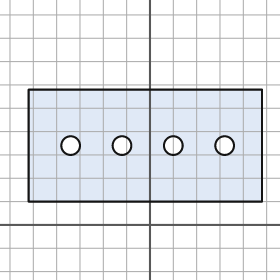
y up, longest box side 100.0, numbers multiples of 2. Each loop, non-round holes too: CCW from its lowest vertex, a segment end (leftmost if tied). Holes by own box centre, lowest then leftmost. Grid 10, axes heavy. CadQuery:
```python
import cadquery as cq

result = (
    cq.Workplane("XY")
    .moveTo(-52.0, 10.0)
    .lineTo(48.0, 10.0)
    .lineTo(48.0, 58.0)
    .lineTo(-52.0, 58.0)
    .close()
    .moveTo(-34.0, 34.0)
    .circle(4.0)
    .moveTo(-12.0, 34.0)
    .circle(4.0)
    .moveTo(10.0, 34.0)
    .circle(4.0)
    .moveTo(32.0, 34.0)
    .circle(4.0)
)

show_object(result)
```